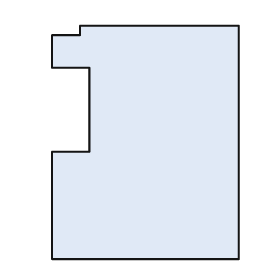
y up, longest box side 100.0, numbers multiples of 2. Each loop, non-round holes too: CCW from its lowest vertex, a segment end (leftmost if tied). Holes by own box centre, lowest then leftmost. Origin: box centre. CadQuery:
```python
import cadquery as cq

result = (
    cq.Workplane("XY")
    .moveTo(-40.0, -50.0)
    .lineTo(40.0, -50.0)
    .lineTo(40.0, 50.0)
    .lineTo(-28.0, 50.0)
    .lineTo(-28.0, 46.0)
    .lineTo(-40.0, 46.0)
    .lineTo(-40.0, 32.0)
    .lineTo(-24.0, 32.0)
    .lineTo(-24.0, -4.0)
    .lineTo(-40.0, -4.0)
    .close()
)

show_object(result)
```